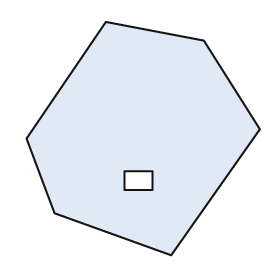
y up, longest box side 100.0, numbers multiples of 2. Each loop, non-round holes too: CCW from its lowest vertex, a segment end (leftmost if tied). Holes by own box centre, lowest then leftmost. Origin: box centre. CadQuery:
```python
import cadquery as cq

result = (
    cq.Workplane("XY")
    .moveTo(12.0, -50.0)
    .lineTo(50.0, 4.0)
    .lineTo(26.0, 42.0)
    .lineTo(-16.0, 50.0)
    .lineTo(-50.0, 0.0)
    .lineTo(-38.0, -32.0)
    .close()
    .moveTo(-8.0, -22.0)
    .lineTo(4.0, -22.0)
    .lineTo(4.0, -14.0)
    .lineTo(-8.0, -14.0)
    .close()
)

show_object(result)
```